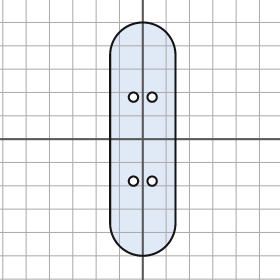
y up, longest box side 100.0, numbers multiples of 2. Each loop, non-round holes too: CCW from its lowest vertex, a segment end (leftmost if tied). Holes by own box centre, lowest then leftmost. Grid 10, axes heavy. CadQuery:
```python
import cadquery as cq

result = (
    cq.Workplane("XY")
    .moveTo(-14.0, -36.0)
    .threePointArc((0.0, -50.0), (14.0, -36.0))
    .lineTo(14.0, 36.0)
    .threePointArc((0.0, 50.0), (-14.0, 36.0))
    .close()
    .moveTo(-4.0, -18.0)
    .circle(2.0)
    .moveTo(4.0, -18.0)
    .circle(2.0)
    .moveTo(-4.0, 18.0)
    .circle(2.0)
    .moveTo(4.0, 18.0)
    .circle(2.0)
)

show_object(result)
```